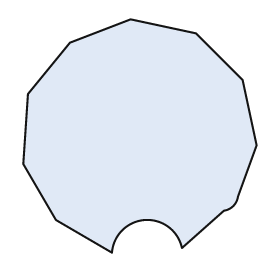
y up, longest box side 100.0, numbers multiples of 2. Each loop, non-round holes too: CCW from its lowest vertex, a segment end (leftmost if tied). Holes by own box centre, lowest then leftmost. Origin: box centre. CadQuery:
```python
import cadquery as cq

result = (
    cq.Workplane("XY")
    .moveTo(-12.0, -50.0)
    .threePointArc((2.0, -36.0), (18.0, -48.0))
    .lineTo(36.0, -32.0)
    .threePointArc((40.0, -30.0), (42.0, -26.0))
    .lineTo(50.0, -4.0)
    .lineTo(44.0, 24.0)
    .lineTo(24.0, 44.0)
    .lineTo(-4.0, 50.0)
    .lineTo(-30.0, 40.0)
    .lineTo(-48.0, 18.0)
    .lineTo(-50.0, -12.0)
    .lineTo(-36.0, -36.0)
    .close()
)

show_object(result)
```